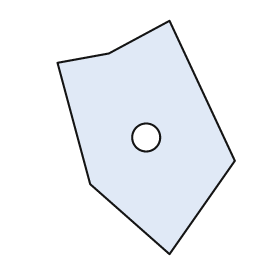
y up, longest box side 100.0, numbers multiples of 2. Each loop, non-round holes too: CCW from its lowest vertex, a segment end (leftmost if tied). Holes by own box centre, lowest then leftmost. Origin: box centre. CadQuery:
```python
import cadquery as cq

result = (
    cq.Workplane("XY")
    .moveTo(10.0, -50.0)
    .lineTo(38.0, -10.0)
    .lineTo(10.0, 50.0)
    .lineTo(-16.0, 36.0)
    .lineTo(-38.0, 32.0)
    .lineTo(-24.0, -20.0)
    .close()
    .moveTo(0.0, 0.0)
    .circle(6.0)
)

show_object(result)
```